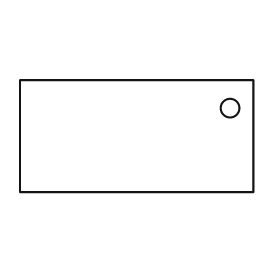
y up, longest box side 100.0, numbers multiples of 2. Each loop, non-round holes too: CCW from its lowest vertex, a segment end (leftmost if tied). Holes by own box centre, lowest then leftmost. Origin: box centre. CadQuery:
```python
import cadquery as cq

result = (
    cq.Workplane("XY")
    .moveTo(-50.0, -24.0)
    .lineTo(50.0, -24.0)
    .lineTo(50.0, 24.0)
    .lineTo(-50.0, 24.0)
    .close()
    .moveTo(40.0, 12.0)
    .circle(4.0)
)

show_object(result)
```